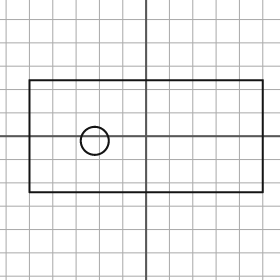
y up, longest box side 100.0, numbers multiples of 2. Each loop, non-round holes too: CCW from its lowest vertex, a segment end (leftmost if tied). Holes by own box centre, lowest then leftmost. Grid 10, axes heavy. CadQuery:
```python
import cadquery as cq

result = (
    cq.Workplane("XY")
    .moveTo(-50.0, -24.0)
    .lineTo(50.0, -24.0)
    .lineTo(50.0, 24.0)
    .lineTo(-50.0, 24.0)
    .close()
    .moveTo(-22.0, -2.0)
    .circle(6.0)
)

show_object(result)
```